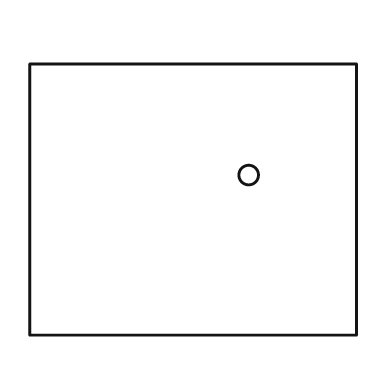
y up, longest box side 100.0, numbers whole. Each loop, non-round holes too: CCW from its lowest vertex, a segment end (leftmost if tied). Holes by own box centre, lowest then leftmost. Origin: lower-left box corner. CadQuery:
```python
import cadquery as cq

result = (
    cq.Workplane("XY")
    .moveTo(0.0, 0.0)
    .lineTo(100.0, 0.0)
    .lineTo(100.0, 83.0)
    .lineTo(0.0, 83.0)
    .close()
    .moveTo(67.0, 49.0)
    .circle(3.0)
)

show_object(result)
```